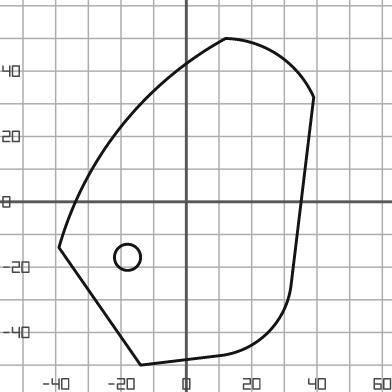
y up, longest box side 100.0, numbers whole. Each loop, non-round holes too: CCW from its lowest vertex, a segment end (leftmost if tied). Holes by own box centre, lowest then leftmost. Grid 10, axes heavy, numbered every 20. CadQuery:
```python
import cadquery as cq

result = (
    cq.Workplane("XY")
    .moveTo(-14.0, -50.0)
    .lineTo(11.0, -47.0)
    .threePointArc((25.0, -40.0), (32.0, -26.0))
    .lineTo(39.0, 32.0)
    .threePointArc((28.0, 45.0), (12.0, 50.0))
    .threePointArc((-20.0, 23.0), (-39.0, -14.0))
    .close()
    .moveTo(-18.0, -17.0)
    .circle(4.0)
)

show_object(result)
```